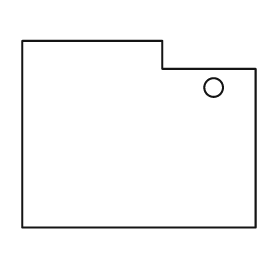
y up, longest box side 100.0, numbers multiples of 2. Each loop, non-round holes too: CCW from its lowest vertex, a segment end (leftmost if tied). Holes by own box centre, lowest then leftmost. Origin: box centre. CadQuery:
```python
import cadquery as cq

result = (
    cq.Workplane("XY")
    .moveTo(-50.0, -40.0)
    .lineTo(50.0, -40.0)
    .lineTo(50.0, 28.0)
    .lineTo(10.0, 28.0)
    .lineTo(10.0, 40.0)
    .lineTo(-50.0, 40.0)
    .close()
    .moveTo(32.0, 20.0)
    .circle(4.0)
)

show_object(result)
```